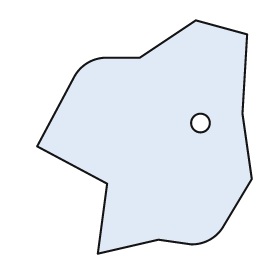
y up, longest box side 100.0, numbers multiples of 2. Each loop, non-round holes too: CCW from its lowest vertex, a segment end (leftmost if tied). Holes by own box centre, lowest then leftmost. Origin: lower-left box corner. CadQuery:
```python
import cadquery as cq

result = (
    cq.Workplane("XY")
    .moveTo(26.0, 0.0)
    .lineTo(52.0, 6.0)
    .lineTo(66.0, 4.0)
    .threePointArc((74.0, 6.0), (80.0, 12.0))
    .lineTo(92.0, 32.0)
    .lineTo(88.0, 60.0)
    .lineTo(90.0, 94.0)
    .lineTo(68.0, 100.0)
    .lineTo(44.0, 84.0)
    .lineTo(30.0, 84.0)
    .threePointArc((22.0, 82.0), (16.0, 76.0))
    .lineTo(0.0, 46.0)
    .lineTo(30.0, 30.0)
    .close()
    .moveTo(70.0, 56.0)
    .circle(4.0)
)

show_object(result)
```